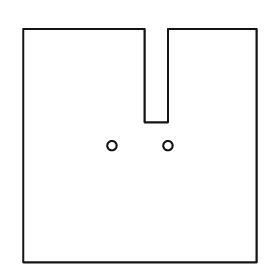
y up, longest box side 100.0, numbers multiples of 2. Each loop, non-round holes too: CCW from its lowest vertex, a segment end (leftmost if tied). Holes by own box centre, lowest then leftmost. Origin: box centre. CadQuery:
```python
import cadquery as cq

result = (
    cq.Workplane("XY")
    .moveTo(-50.0, -50.0)
    .lineTo(50.0, -50.0)
    .lineTo(50.0, 50.0)
    .lineTo(12.0, 50.0)
    .lineTo(12.0, 10.0)
    .lineTo(2.0, 10.0)
    .lineTo(2.0, 50.0)
    .lineTo(-50.0, 50.0)
    .close()
    .moveTo(-12.0, 0.0)
    .circle(2.0)
    .moveTo(12.0, 0.0)
    .circle(2.0)
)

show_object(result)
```